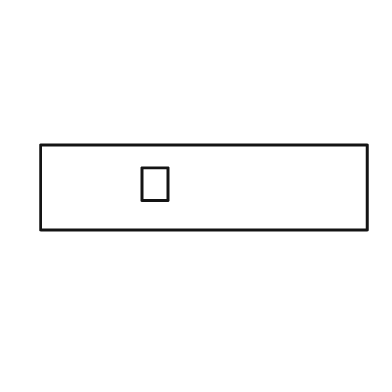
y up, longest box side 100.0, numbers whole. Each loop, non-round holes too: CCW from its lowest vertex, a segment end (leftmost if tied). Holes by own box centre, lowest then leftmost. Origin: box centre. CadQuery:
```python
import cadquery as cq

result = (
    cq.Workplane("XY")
    .moveTo(-50.0, -13.0)
    .lineTo(50.0, -13.0)
    .lineTo(50.0, 13.0)
    .lineTo(-50.0, 13.0)
    .close()
    .moveTo(-19.0, -4.0)
    .lineTo(-11.0, -4.0)
    .lineTo(-11.0, 6.0)
    .lineTo(-19.0, 6.0)
    .close()
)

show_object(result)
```